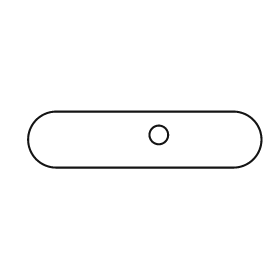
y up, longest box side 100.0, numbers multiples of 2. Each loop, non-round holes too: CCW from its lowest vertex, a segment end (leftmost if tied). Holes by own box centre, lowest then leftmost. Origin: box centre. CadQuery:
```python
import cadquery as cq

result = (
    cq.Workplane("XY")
    .moveTo(-38.0, -12.0)
    .lineTo(38.0, -12.0)
    .threePointArc((50.0, 0.0), (38.0, 12.0))
    .lineTo(-38.0, 12.0)
    .threePointArc((-50.0, 0.0), (-38.0, -12.0))
    .close()
    .moveTo(6.0, 2.0)
    .circle(4.0)
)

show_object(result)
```